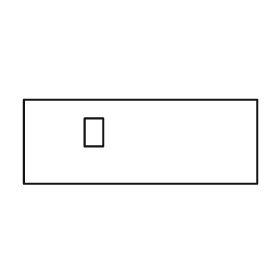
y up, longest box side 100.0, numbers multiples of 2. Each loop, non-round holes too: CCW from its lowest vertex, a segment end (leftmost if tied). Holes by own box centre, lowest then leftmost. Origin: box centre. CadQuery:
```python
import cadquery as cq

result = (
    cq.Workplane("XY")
    .moveTo(-50.0, -18.0)
    .lineTo(50.0, -18.0)
    .lineTo(50.0, 18.0)
    .lineTo(-50.0, 18.0)
    .close()
    .moveTo(-24.0, -2.0)
    .lineTo(-16.0, -2.0)
    .lineTo(-16.0, 10.0)
    .lineTo(-24.0, 10.0)
    .close()
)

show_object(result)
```